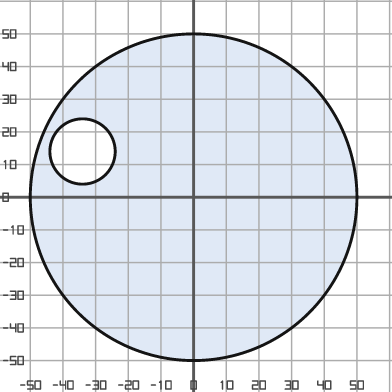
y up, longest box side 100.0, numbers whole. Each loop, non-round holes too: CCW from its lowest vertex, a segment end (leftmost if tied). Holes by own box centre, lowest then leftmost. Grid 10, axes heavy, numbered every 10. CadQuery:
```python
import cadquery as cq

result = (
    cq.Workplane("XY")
    .moveTo(0.0, 0.0)
    .circle(50.0)
    .moveTo(-34.0, 14.0)
    .circle(10.0)
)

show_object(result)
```